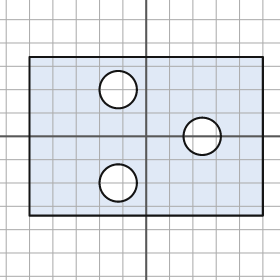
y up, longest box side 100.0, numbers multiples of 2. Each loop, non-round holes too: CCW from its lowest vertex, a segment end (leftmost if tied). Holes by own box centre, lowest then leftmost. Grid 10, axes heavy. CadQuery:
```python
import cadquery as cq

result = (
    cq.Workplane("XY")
    .moveTo(-50.0, -34.0)
    .lineTo(50.0, -34.0)
    .lineTo(50.0, 34.0)
    .lineTo(-50.0, 34.0)
    .close()
    .moveTo(-12.0, -20.0)
    .circle(8.0)
    .moveTo(24.0, 0.0)
    .circle(8.0)
    .moveTo(-12.0, 20.0)
    .circle(8.0)
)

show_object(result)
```